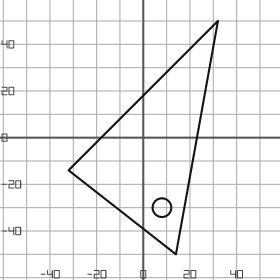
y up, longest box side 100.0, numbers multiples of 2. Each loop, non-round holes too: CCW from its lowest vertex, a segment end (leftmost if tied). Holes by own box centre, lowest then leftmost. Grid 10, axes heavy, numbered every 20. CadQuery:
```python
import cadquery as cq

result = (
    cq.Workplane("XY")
    .moveTo(14.0, -50.0)
    .lineTo(32.0, 50.0)
    .lineTo(-32.0, -14.0)
    .close()
    .moveTo(8.0, -30.0)
    .circle(4.0)
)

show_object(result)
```